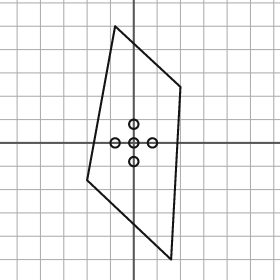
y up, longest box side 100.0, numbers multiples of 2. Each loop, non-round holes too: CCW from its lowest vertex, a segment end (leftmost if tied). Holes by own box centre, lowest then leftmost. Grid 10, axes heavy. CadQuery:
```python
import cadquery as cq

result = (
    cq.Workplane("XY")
    .moveTo(16.0, -50.0)
    .lineTo(20.0, 24.0)
    .lineTo(-8.0, 50.0)
    .lineTo(-20.0, -16.0)
    .close()
    .moveTo(0.0, -8.0)
    .circle(2.0)
    .moveTo(-8.0, 0.0)
    .circle(2.0)
    .moveTo(0.0, 0.0)
    .circle(2.0)
    .moveTo(8.0, 0.0)
    .circle(2.0)
    .moveTo(0.0, 8.0)
    .circle(2.0)
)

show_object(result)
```